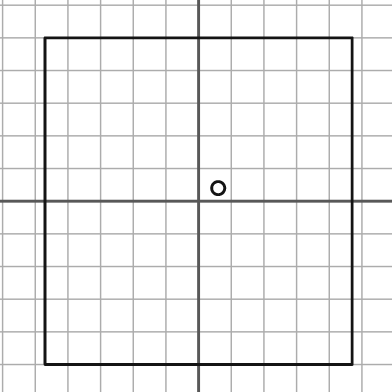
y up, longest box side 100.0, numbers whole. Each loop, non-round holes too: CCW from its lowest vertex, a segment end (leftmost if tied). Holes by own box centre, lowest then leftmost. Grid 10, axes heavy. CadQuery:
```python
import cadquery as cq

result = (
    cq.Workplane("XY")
    .moveTo(-47.0, -50.0)
    .lineTo(47.0, -50.0)
    .lineTo(47.0, 50.0)
    .lineTo(-47.0, 50.0)
    .close()
    .moveTo(6.0, 4.0)
    .circle(2.0)
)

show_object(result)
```